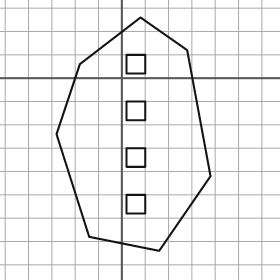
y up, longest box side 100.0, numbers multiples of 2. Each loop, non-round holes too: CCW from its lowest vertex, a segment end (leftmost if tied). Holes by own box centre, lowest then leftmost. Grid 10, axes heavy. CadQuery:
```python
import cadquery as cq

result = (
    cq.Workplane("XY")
    .moveTo(16.0, -74.0)
    .lineTo(38.0, -42.0)
    .lineTo(28.0, 12.0)
    .lineTo(8.0, 26.0)
    .lineTo(-18.0, 6.0)
    .lineTo(-28.0, -24.0)
    .lineTo(-14.0, -68.0)
    .close()
    .moveTo(2.0, -58.0)
    .lineTo(10.0, -58.0)
    .lineTo(10.0, -50.0)
    .lineTo(2.0, -50.0)
    .close()
    .moveTo(2.0, -38.0)
    .lineTo(10.0, -38.0)
    .lineTo(10.0, -30.0)
    .lineTo(2.0, -30.0)
    .close()
    .moveTo(2.0, -18.0)
    .lineTo(10.0, -18.0)
    .lineTo(10.0, -10.0)
    .lineTo(2.0, -10.0)
    .close()
    .moveTo(2.0, 2.0)
    .lineTo(10.0, 2.0)
    .lineTo(10.0, 10.0)
    .lineTo(2.0, 10.0)
    .close()
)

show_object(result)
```